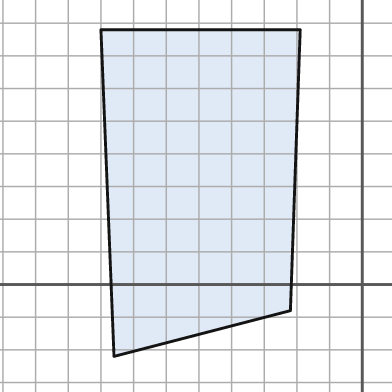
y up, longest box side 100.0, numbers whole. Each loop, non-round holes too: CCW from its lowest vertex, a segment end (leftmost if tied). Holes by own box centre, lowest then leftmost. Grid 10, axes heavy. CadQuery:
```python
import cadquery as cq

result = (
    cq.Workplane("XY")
    .moveTo(-76.0, -22.0)
    .lineTo(-22.0, -8.0)
    .lineTo(-19.0, 78.0)
    .lineTo(-80.0, 78.0)
    .close()
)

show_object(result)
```